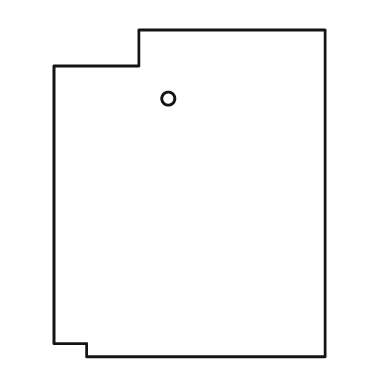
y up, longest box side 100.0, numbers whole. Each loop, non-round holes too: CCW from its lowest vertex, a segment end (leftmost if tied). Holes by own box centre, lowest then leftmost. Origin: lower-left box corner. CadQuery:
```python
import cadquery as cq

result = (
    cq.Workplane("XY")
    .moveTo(10.0, 0.0)
    .lineTo(83.0, 0.0)
    .lineTo(83.0, 100.0)
    .lineTo(26.0, 100.0)
    .lineTo(26.0, 89.0)
    .lineTo(0.0, 89.0)
    .lineTo(0.0, 4.0)
    .lineTo(10.0, 4.0)
    .close()
    .moveTo(35.0, 79.0)
    .circle(2.0)
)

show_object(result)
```